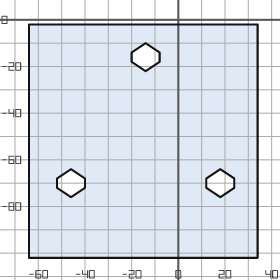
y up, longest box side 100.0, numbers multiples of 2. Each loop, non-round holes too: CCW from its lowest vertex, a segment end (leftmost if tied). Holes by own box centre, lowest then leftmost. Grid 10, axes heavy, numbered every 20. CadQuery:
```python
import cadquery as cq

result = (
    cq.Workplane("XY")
    .moveTo(-64.0, -102.0)
    .lineTo(34.0, -102.0)
    .lineTo(34.0, -2.0)
    .lineTo(-64.0, -2.0)
    .close()
    .moveTo(-46.0, -76.0)
    .lineTo(-40.0, -72.0)
    .lineTo(-40.0, -68.0)
    .lineTo(-46.0, -64.0)
    .lineTo(-52.0, -68.0)
    .lineTo(-52.0, -72.0)
    .close()
    .moveTo(18.0, -76.0)
    .lineTo(24.0, -72.0)
    .lineTo(24.0, -68.0)
    .lineTo(18.0, -64.0)
    .lineTo(12.0, -68.0)
    .lineTo(12.0, -72.0)
    .close()
    .moveTo(-14.0, -22.0)
    .lineTo(-8.0, -18.0)
    .lineTo(-8.0, -14.0)
    .lineTo(-14.0, -10.0)
    .lineTo(-20.0, -14.0)
    .lineTo(-20.0, -18.0)
    .close()
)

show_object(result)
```